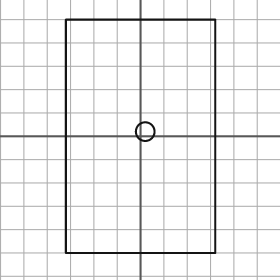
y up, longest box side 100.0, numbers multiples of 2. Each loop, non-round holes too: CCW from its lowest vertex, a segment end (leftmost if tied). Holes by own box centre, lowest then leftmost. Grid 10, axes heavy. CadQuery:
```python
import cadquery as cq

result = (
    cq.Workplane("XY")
    .moveTo(-32.0, -50.0)
    .lineTo(32.0, -50.0)
    .lineTo(32.0, 50.0)
    .lineTo(-32.0, 50.0)
    .close()
    .moveTo(2.0, 2.0)
    .circle(4.0)
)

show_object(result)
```